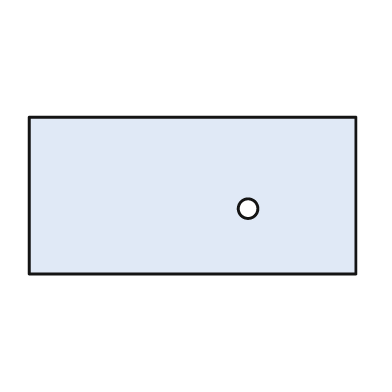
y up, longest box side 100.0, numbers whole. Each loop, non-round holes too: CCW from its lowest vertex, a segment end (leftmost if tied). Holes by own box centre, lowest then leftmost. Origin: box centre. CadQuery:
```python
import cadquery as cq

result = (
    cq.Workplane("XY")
    .moveTo(-50.0, -24.0)
    .lineTo(50.0, -24.0)
    .lineTo(50.0, 24.0)
    .lineTo(-50.0, 24.0)
    .close()
    .moveTo(17.0, -4.0)
    .circle(3.0)
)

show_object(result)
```